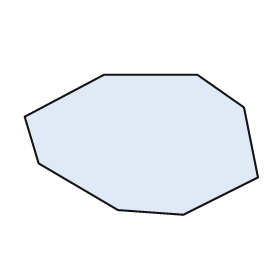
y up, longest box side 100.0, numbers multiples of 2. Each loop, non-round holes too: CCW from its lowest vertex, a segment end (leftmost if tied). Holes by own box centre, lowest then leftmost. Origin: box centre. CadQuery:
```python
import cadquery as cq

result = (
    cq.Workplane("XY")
    .moveTo(18.0, -30.0)
    .lineTo(50.0, -14.0)
    .lineTo(44.0, 16.0)
    .lineTo(24.0, 30.0)
    .lineTo(-16.0, 30.0)
    .lineTo(-50.0, 12.0)
    .lineTo(-44.0, -8.0)
    .lineTo(-10.0, -28.0)
    .close()
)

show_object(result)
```